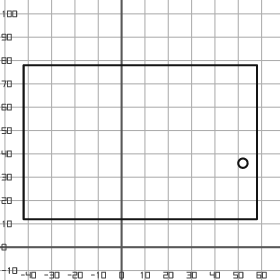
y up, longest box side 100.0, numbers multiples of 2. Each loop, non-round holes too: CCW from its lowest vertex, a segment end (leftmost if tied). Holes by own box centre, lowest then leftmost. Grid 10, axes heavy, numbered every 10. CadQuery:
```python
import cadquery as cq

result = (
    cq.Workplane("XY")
    .moveTo(-42.0, 12.0)
    .lineTo(58.0, 12.0)
    .lineTo(58.0, 78.0)
    .lineTo(-42.0, 78.0)
    .close()
    .moveTo(52.0, 36.0)
    .circle(2.0)
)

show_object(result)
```